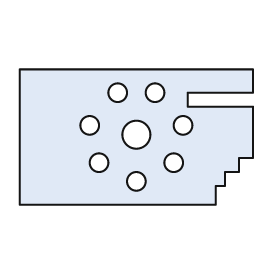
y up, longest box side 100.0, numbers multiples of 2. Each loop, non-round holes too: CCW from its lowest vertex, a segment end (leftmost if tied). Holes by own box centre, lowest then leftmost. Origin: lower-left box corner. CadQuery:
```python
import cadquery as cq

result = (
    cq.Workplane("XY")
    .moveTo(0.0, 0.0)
    .lineTo(84.0, 0.0)
    .lineTo(84.0, 8.0)
    .lineTo(88.0, 8.0)
    .lineTo(88.0, 14.0)
    .lineTo(94.0, 14.0)
    .lineTo(94.0, 20.0)
    .lineTo(100.0, 20.0)
    .lineTo(100.0, 42.0)
    .lineTo(72.0, 42.0)
    .lineTo(72.0, 48.0)
    .lineTo(100.0, 48.0)
    .lineTo(100.0, 58.0)
    .lineTo(0.0, 58.0)
    .close()
    .moveTo(50.0, 10.0)
    .circle(4.0)
    .moveTo(34.0, 18.0)
    .circle(4.0)
    .moveTo(66.0, 18.0)
    .circle(4.0)
    .moveTo(50.0, 30.0)
    .circle(6.0)
    .moveTo(30.0, 34.0)
    .circle(4.0)
    .moveTo(70.0, 34.0)
    .circle(4.0)
    .moveTo(42.0, 48.0)
    .circle(4.0)
    .moveTo(58.0, 48.0)
    .circle(4.0)
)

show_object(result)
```